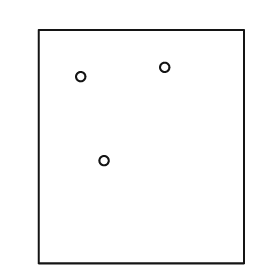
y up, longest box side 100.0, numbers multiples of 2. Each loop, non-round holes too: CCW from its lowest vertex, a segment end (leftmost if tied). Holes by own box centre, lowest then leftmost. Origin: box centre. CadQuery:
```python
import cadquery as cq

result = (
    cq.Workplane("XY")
    .moveTo(-44.0, -50.0)
    .lineTo(44.0, -50.0)
    .lineTo(44.0, 50.0)
    .lineTo(-44.0, 50.0)
    .close()
    .moveTo(-16.0, -6.0)
    .circle(2.0)
    .moveTo(-26.0, 30.0)
    .circle(2.0)
    .moveTo(10.0, 34.0)
    .circle(2.0)
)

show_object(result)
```